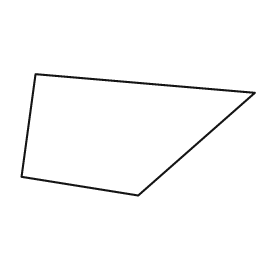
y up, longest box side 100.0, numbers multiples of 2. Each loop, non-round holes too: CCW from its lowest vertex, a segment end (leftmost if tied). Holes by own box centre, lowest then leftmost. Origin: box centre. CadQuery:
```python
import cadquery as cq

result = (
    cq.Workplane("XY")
    .moveTo(0.0, -26.0)
    .lineTo(50.0, 18.0)
    .lineTo(-44.0, 26.0)
    .lineTo(-50.0, -18.0)
    .close()
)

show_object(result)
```